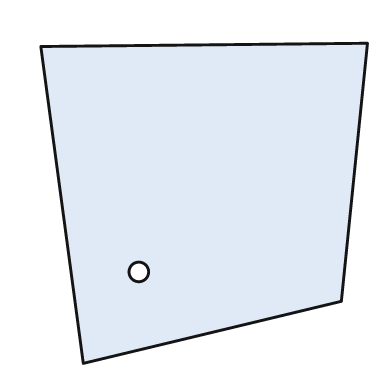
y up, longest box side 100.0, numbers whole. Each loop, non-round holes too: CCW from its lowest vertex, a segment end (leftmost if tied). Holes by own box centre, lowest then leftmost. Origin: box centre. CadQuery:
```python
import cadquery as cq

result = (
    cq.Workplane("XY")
    .moveTo(-37.0, -49.0)
    .lineTo(42.0, -30.0)
    .lineTo(50.0, 49.0)
    .lineTo(-50.0, 48.0)
    .close()
    .moveTo(-20.0, -21.0)
    .circle(3.0)
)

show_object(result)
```